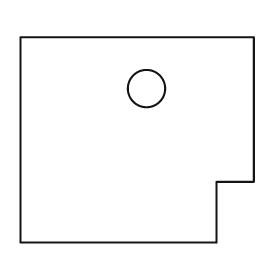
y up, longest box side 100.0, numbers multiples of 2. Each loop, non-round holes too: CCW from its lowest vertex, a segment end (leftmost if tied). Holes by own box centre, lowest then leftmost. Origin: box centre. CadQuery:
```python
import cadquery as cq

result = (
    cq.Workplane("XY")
    .moveTo(-50.0, -44.0)
    .lineTo(34.0, -44.0)
    .lineTo(34.0, -18.0)
    .lineTo(50.0, -18.0)
    .lineTo(50.0, 44.0)
    .lineTo(-50.0, 44.0)
    .close()
    .moveTo(4.0, 22.0)
    .circle(8.0)
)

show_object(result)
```